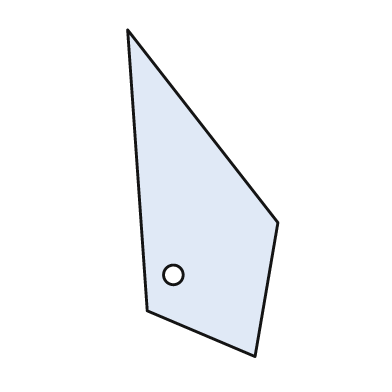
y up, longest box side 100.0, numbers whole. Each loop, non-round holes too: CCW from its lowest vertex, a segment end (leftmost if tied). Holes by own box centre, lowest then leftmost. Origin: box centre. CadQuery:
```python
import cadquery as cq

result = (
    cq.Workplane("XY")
    .moveTo(16.0, -50.0)
    .lineTo(23.0, -9.0)
    .lineTo(-23.0, 50.0)
    .lineTo(-17.0, -36.0)
    .close()
    .moveTo(-9.0, -25.0)
    .circle(3.0)
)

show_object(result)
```